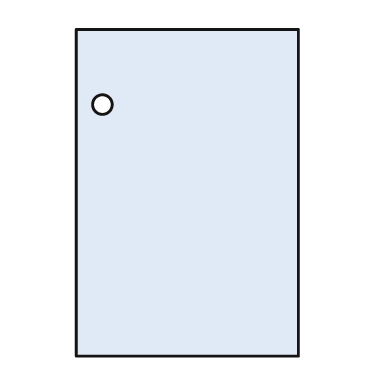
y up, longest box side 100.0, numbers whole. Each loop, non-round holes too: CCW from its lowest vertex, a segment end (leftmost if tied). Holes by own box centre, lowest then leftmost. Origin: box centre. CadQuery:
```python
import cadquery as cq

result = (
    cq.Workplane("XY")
    .moveTo(-34.0, -50.0)
    .lineTo(34.0, -50.0)
    .lineTo(34.0, 50.0)
    .lineTo(-34.0, 50.0)
    .close()
    .moveTo(-26.0, 27.0)
    .circle(3.0)
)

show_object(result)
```